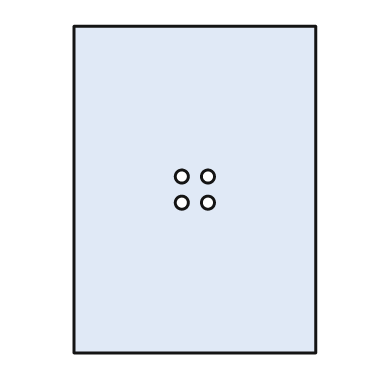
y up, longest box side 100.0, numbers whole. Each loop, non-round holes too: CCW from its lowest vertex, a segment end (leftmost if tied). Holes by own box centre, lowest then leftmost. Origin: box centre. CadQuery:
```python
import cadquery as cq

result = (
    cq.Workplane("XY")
    .moveTo(-37.0, -50.0)
    .lineTo(37.0, -50.0)
    .lineTo(37.0, 50.0)
    .lineTo(-37.0, 50.0)
    .close()
    .moveTo(-4.0, -4.0)
    .circle(2.0)
    .moveTo(4.0, -4.0)
    .circle(2.0)
    .moveTo(-4.0, 4.0)
    .circle(2.0)
    .moveTo(4.0, 4.0)
    .circle(2.0)
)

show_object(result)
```